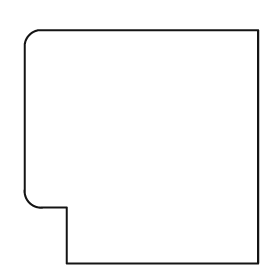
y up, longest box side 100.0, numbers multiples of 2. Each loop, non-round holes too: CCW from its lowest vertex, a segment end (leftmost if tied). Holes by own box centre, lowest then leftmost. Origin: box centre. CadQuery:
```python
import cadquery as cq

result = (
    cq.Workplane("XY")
    .moveTo(-32.0, -50.0)
    .lineTo(50.0, -50.0)
    .lineTo(50.0, 50.0)
    .lineTo(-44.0, 50.0)
    .threePointArc((-48.0, 48.0), (-50.0, 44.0))
    .lineTo(-50.0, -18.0)
    .threePointArc((-48.0, -24.0), (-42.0, -26.0))
    .lineTo(-32.0, -26.0)
    .close()
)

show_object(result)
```